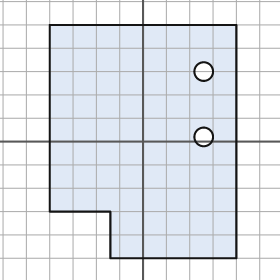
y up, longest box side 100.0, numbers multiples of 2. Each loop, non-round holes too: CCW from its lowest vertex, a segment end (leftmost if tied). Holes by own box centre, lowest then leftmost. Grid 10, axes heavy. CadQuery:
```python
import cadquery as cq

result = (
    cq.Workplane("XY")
    .moveTo(-14.0, -50.0)
    .lineTo(40.0, -50.0)
    .lineTo(40.0, 50.0)
    .lineTo(-40.0, 50.0)
    .lineTo(-40.0, -30.0)
    .lineTo(-14.0, -30.0)
    .close()
    .moveTo(26.0, 2.0)
    .circle(4.0)
    .moveTo(26.0, 30.0)
    .circle(4.0)
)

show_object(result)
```